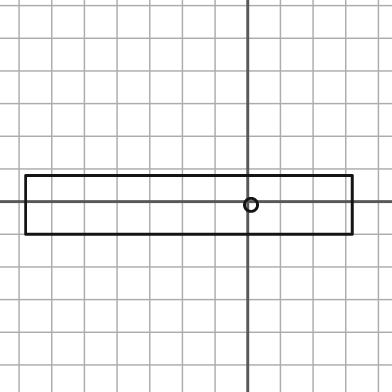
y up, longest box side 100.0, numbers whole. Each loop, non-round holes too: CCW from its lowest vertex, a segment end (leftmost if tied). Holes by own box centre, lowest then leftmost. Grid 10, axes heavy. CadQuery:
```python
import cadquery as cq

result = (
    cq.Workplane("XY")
    .moveTo(-68.0, -10.0)
    .lineTo(32.0, -10.0)
    .lineTo(32.0, 8.0)
    .lineTo(-68.0, 8.0)
    .close()
    .moveTo(1.0, -1.0)
    .circle(2.0)
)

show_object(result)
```